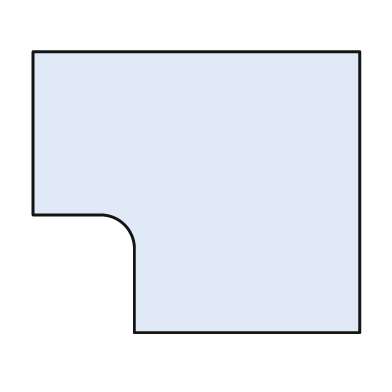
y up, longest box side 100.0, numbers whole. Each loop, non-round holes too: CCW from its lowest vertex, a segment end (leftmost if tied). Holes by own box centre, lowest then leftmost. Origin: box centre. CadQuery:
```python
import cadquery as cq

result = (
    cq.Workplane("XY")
    .moveTo(-19.0, -43.0)
    .lineTo(50.0, -43.0)
    .lineTo(50.0, 43.0)
    .lineTo(-50.0, 43.0)
    .lineTo(-50.0, -7.0)
    .lineTo(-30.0, -7.0)
    .threePointArc((-22.0, -10.0), (-19.0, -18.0))
    .close()
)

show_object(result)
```